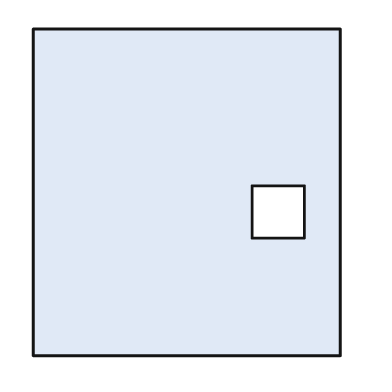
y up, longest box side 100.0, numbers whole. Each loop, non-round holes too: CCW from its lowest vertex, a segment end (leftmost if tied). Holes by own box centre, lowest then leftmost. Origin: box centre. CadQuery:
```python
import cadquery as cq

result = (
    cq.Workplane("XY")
    .moveTo(-47.0, -50.0)
    .lineTo(47.0, -50.0)
    .lineTo(47.0, 50.0)
    .lineTo(-47.0, 50.0)
    .close()
    .moveTo(20.0, -14.0)
    .lineTo(36.0, -14.0)
    .lineTo(36.0, 2.0)
    .lineTo(20.0, 2.0)
    .close()
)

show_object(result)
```